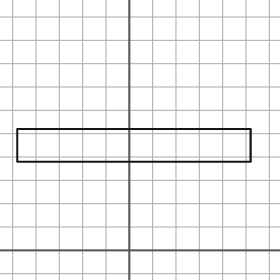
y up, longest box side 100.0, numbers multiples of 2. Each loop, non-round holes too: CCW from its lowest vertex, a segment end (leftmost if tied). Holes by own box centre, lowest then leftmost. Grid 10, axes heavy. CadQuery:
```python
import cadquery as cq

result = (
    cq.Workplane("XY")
    .moveTo(-48.0, 38.0)
    .lineTo(52.0, 38.0)
    .lineTo(52.0, 52.0)
    .lineTo(-48.0, 52.0)
    .close()
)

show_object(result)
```